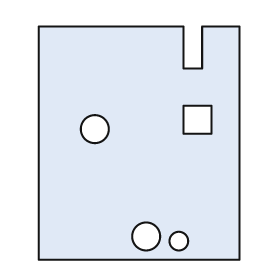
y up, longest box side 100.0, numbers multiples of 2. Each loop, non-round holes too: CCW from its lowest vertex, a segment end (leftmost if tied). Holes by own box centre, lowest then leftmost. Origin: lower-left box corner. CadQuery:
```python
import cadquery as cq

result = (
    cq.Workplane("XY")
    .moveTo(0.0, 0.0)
    .lineTo(86.0, 0.0)
    .lineTo(86.0, 100.0)
    .lineTo(70.0, 100.0)
    .lineTo(70.0, 82.0)
    .lineTo(62.0, 82.0)
    .lineTo(62.0, 100.0)
    .lineTo(0.0, 100.0)
    .close()
    .moveTo(60.0, 8.0)
    .circle(4.0)
    .moveTo(46.0, 10.0)
    .circle(6.0)
    .moveTo(24.0, 56.0)
    .circle(6.0)
    .moveTo(62.0, 54.0)
    .lineTo(74.0, 54.0)
    .lineTo(74.0, 66.0)
    .lineTo(62.0, 66.0)
    .close()
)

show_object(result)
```